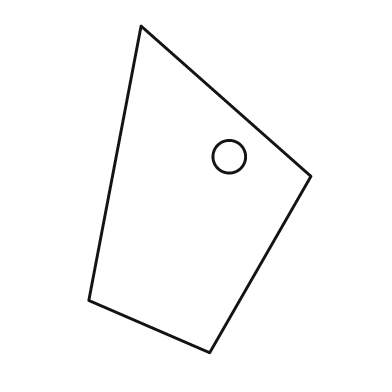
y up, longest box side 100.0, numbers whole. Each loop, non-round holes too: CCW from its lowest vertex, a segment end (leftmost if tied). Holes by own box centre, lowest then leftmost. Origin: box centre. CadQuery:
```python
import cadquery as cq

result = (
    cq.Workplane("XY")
    .moveTo(3.0, -50.0)
    .lineTo(34.0, 4.0)
    .lineTo(-18.0, 50.0)
    .lineTo(-34.0, -34.0)
    .close()
    .moveTo(9.0, 10.0)
    .circle(5.0)
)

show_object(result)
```